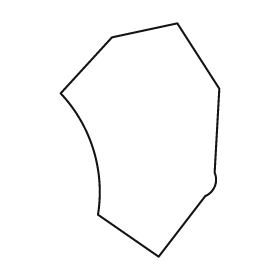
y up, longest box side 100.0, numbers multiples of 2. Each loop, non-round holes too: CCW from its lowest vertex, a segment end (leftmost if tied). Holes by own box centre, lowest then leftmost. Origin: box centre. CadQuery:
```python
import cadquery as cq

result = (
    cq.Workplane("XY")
    .moveTo(8.0, -50.0)
    .lineTo(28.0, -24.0)
    .threePointArc((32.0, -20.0), (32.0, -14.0))
    .lineTo(34.0, 22.0)
    .lineTo(16.0, 50.0)
    .lineTo(-12.0, 44.0)
    .lineTo(-34.0, 20.0)
    .threePointArc((-20.0, -4.0), (-18.0, -32.0))
    .close()
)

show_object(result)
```